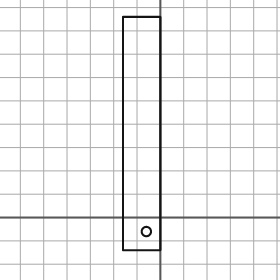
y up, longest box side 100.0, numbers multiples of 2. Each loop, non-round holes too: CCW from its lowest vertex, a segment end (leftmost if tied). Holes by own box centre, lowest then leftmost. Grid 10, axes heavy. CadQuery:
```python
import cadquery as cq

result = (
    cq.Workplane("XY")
    .moveTo(-16.0, -14.0)
    .lineTo(0.0, -14.0)
    .lineTo(0.0, 86.0)
    .lineTo(-16.0, 86.0)
    .close()
    .moveTo(-6.0, -6.0)
    .circle(2.0)
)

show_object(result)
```